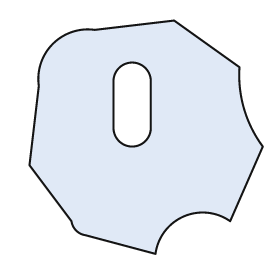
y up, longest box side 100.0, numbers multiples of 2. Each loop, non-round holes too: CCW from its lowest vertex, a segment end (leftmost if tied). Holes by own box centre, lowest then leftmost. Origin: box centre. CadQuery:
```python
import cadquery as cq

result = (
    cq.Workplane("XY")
    .moveTo(4.0, -50.0)
    .threePointArc((16.0, -34.0), (36.0, -36.0))
    .lineTo(50.0, -4.0)
    .threePointArc((42.0, 12.0), (40.0, 30.0))
    .lineTo(12.0, 50.0)
    .lineTo(-22.0, 46.0)
    .threePointArc((-40.0, 40.0), (-46.0, 22.0))
    .lineTo(-50.0, -12.0)
    .lineTo(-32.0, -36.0)
    .threePointArc((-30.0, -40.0), (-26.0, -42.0))
    .close()
    .moveTo(-14.0, 4.0)
    .threePointArc((-6.0, -4.0), (2.0, 4.0))
    .lineTo(2.0, 24.0)
    .threePointArc((-6.0, 32.0), (-14.0, 24.0))
    .close()
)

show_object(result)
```